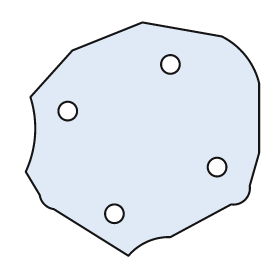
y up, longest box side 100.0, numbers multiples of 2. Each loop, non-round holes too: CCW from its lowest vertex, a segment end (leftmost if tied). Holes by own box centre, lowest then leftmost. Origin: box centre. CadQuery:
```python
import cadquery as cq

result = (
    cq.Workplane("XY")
    .moveTo(-6.0, -50.0)
    .threePointArc((2.0, -44.0), (12.0, -42.0))
    .lineTo(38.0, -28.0)
    .threePointArc((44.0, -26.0), (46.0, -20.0))
    .lineTo(50.0, -6.0)
    .lineTo(50.0, 24.0)
    .threePointArc((44.0, 36.0), (34.0, 44.0))
    .lineTo(0.0, 50.0)
    .lineTo(-30.0, 38.0)
    .lineTo(-48.0, 18.0)
    .threePointArc((-46.0, 2.0), (-50.0, -14.0))
    .lineTo(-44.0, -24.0)
    .threePointArc((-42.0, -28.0), (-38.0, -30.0))
    .close()
    .moveTo(-12.0, -32.0)
    .circle(4.0)
    .moveTo(32.0, -12.0)
    .circle(4.0)
    .moveTo(-32.0, 12.0)
    .circle(4.0)
    .moveTo(12.0, 32.0)
    .circle(4.0)
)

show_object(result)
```